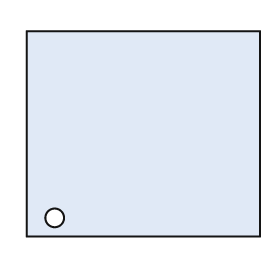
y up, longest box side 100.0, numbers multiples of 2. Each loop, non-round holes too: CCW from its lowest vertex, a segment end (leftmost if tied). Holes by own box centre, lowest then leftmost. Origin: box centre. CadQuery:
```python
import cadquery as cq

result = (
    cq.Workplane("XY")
    .moveTo(-50.0, -44.0)
    .lineTo(50.0, -44.0)
    .lineTo(50.0, 44.0)
    .lineTo(-50.0, 44.0)
    .close()
    .moveTo(-38.0, -36.0)
    .circle(4.0)
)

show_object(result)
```